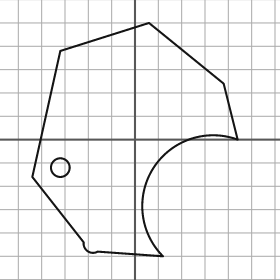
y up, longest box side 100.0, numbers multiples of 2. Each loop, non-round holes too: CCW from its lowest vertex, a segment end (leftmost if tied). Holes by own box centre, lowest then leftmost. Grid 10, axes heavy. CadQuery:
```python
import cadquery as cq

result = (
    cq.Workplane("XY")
    .moveTo(12.0, -50.0)
    .threePointArc((8.0, -12.0), (44.0, 0.0))
    .lineTo(38.0, 24.0)
    .lineTo(6.0, 50.0)
    .lineTo(-32.0, 38.0)
    .lineTo(-44.0, -16.0)
    .lineTo(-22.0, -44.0)
    .threePointArc((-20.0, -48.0), (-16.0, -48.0))
    .close()
    .moveTo(-32.0, -12.0)
    .circle(4.0)
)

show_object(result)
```